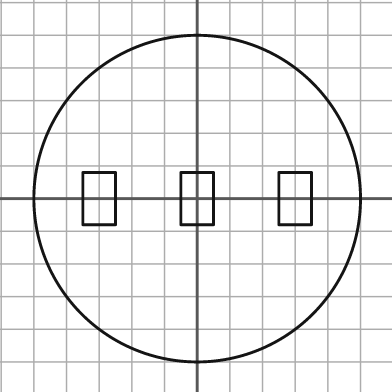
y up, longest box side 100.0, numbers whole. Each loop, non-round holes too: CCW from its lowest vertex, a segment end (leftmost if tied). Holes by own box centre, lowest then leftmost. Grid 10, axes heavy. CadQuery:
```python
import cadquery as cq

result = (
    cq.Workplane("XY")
    .moveTo(0.0, 0.0)
    .circle(50.0)
    .moveTo(-35.0, -8.0)
    .lineTo(-25.0, -8.0)
    .lineTo(-25.0, 8.0)
    .lineTo(-35.0, 8.0)
    .close()
    .moveTo(-5.0, -8.0)
    .lineTo(5.0, -8.0)
    .lineTo(5.0, 8.0)
    .lineTo(-5.0, 8.0)
    .close()
    .moveTo(25.0, -8.0)
    .lineTo(35.0, -8.0)
    .lineTo(35.0, 8.0)
    .lineTo(25.0, 8.0)
    .close()
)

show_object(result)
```